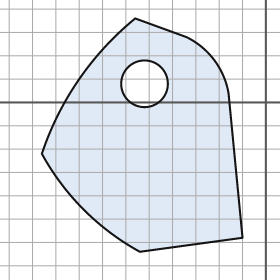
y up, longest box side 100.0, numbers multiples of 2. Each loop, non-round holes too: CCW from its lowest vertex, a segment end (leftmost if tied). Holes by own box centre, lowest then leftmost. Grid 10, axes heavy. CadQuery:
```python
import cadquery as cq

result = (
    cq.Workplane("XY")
    .moveTo(-54.0, -64.0)
    .lineTo(-10.0, -58.0)
    .lineTo(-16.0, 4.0)
    .threePointArc((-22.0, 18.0), (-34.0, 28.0))
    .lineTo(-56.0, 36.0)
    .threePointArc((-80.0, 10.0), (-96.0, -22.0))
    .threePointArc((-78.0, -46.0), (-54.0, -64.0))
    .close()
    .moveTo(-52.0, 8.0)
    .circle(10.0)
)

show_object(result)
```